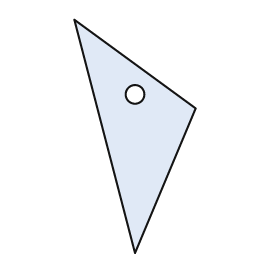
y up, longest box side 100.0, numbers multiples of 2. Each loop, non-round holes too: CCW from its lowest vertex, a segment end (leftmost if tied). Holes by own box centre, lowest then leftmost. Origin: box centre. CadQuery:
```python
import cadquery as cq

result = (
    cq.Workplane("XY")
    .moveTo(0.0, -50.0)
    .lineTo(26.0, 12.0)
    .lineTo(-26.0, 50.0)
    .close()
    .moveTo(0.0, 18.0)
    .circle(4.0)
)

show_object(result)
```